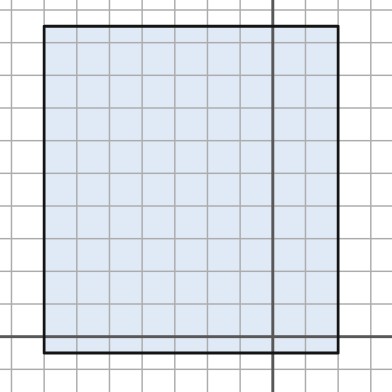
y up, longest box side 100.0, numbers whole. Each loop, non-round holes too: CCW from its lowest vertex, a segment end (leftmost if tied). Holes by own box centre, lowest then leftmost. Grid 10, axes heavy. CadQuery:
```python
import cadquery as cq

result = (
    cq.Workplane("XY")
    .moveTo(-70.0, -5.0)
    .lineTo(20.0, -5.0)
    .lineTo(20.0, 95.0)
    .lineTo(-70.0, 95.0)
    .close()
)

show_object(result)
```